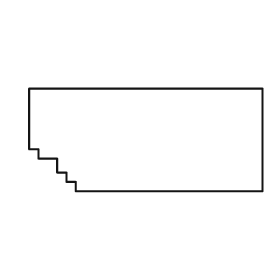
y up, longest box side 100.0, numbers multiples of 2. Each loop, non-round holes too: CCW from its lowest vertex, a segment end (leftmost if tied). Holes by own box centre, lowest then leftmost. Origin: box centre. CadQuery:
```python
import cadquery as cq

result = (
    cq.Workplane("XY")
    .moveTo(-30.0, -22.0)
    .lineTo(50.0, -22.0)
    .lineTo(50.0, 22.0)
    .lineTo(-50.0, 22.0)
    .lineTo(-50.0, -4.0)
    .lineTo(-46.0, -4.0)
    .lineTo(-46.0, -8.0)
    .lineTo(-38.0, -8.0)
    .lineTo(-38.0, -14.0)
    .lineTo(-34.0, -14.0)
    .lineTo(-34.0, -18.0)
    .lineTo(-30.0, -18.0)
    .close()
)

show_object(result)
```